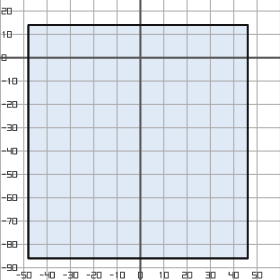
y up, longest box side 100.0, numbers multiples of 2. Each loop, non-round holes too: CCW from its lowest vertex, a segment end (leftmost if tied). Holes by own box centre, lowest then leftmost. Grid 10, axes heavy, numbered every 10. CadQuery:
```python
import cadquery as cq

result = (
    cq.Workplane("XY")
    .moveTo(-48.0, -86.0)
    .lineTo(46.0, -86.0)
    .lineTo(46.0, 14.0)
    .lineTo(-48.0, 14.0)
    .close()
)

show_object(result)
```